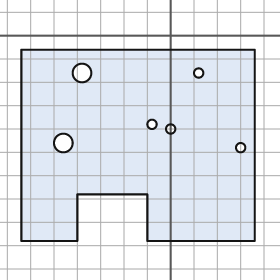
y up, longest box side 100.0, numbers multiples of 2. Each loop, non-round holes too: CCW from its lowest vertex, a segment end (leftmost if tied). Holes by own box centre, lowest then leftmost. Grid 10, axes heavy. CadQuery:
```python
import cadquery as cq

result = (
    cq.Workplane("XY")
    .moveTo(-64.0, -88.0)
    .lineTo(-40.0, -88.0)
    .lineTo(-40.0, -68.0)
    .lineTo(-10.0, -68.0)
    .lineTo(-10.0, -88.0)
    .lineTo(36.0, -88.0)
    .lineTo(36.0, -6.0)
    .lineTo(-64.0, -6.0)
    .close()
    .moveTo(30.0, -48.0)
    .circle(2.0)
    .moveTo(-46.0, -46.0)
    .circle(4.0)
    .moveTo(0.0, -40.0)
    .circle(2.0)
    .moveTo(-8.0, -38.0)
    .circle(2.0)
    .moveTo(-38.0, -16.0)
    .circle(4.0)
    .moveTo(12.0, -16.0)
    .circle(2.0)
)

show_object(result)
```